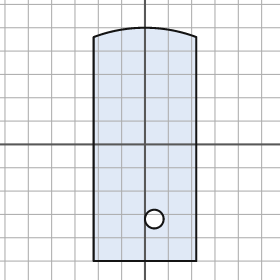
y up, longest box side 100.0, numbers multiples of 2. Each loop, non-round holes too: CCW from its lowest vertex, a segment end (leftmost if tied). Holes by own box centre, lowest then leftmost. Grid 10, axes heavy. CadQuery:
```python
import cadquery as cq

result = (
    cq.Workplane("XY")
    .moveTo(-22.0, -50.0)
    .lineTo(22.0, -50.0)
    .lineTo(22.0, 46.0)
    .threePointArc((0.0, 50.0), (-22.0, 46.0))
    .close()
    .moveTo(4.0, -32.0)
    .circle(4.0)
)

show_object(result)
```